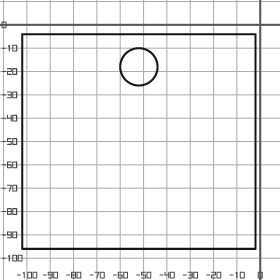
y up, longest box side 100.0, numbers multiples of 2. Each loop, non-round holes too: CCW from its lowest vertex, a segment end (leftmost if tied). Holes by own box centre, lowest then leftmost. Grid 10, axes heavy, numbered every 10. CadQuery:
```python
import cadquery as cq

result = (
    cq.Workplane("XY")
    .moveTo(-102.0, -96.0)
    .lineTo(-2.0, -96.0)
    .lineTo(-2.0, -4.0)
    .lineTo(-102.0, -4.0)
    .close()
    .moveTo(-52.0, -18.0)
    .circle(8.0)
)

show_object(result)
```